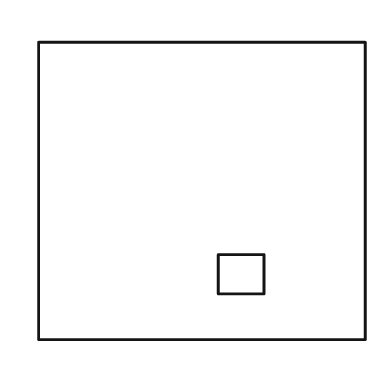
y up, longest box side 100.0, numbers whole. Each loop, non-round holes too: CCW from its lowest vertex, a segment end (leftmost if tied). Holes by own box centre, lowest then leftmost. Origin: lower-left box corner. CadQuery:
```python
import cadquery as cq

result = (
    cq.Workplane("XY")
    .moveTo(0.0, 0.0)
    .lineTo(100.0, 0.0)
    .lineTo(100.0, 91.0)
    .lineTo(0.0, 91.0)
    .close()
    .moveTo(55.0, 14.0)
    .lineTo(69.0, 14.0)
    .lineTo(69.0, 26.0)
    .lineTo(55.0, 26.0)
    .close()
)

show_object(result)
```